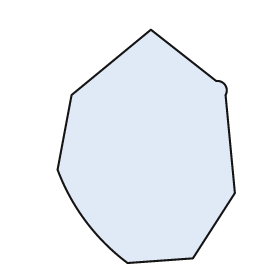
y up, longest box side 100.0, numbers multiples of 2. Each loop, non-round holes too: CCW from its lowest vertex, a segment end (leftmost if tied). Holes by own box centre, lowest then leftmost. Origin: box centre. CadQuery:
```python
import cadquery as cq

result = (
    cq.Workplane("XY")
    .moveTo(-8.0, -50.0)
    .lineTo(20.0, -48.0)
    .lineTo(38.0, -20.0)
    .lineTo(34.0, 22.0)
    .threePointArc((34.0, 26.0), (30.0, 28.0))
    .lineTo(2.0, 50.0)
    .lineTo(-32.0, 22.0)
    .lineTo(-38.0, -10.0)
    .threePointArc((-26.0, -32.0), (-8.0, -50.0))
    .close()
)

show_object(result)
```